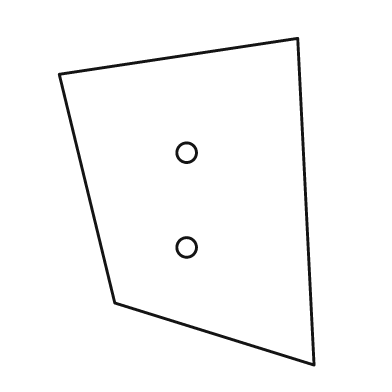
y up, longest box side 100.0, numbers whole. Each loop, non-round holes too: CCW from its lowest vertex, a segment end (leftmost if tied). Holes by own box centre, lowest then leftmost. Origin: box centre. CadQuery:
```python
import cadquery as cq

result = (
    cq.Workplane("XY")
    .moveTo(39.0, -50.0)
    .lineTo(34.0, 50.0)
    .lineTo(-39.0, 39.0)
    .lineTo(-22.0, -31.0)
    .close()
    .moveTo(0.0, -14.0)
    .circle(3.0)
    .moveTo(0.0, 15.0)
    .circle(3.0)
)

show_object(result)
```